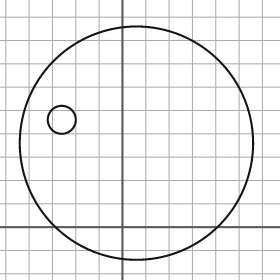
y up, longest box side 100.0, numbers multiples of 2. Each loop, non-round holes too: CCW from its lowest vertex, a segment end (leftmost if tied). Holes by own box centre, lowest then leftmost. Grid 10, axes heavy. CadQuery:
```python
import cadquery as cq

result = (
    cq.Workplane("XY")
    .moveTo(6.0, 36.0)
    .circle(50.0)
    .moveTo(-26.0, 46.0)
    .circle(6.0)
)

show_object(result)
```